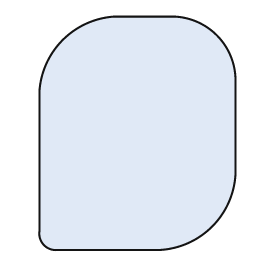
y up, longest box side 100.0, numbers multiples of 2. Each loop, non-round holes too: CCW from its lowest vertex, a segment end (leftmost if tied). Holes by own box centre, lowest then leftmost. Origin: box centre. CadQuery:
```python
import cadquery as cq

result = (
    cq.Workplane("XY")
    .moveTo(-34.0, -50.0)
    .lineTo(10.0, -50.0)
    .threePointArc((32.0, -40.0), (42.0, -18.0))
    .lineTo(42.0, 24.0)
    .threePointArc((34.0, 42.0), (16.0, 50.0))
    .lineTo(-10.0, 50.0)
    .threePointArc((-32.0, 40.0), (-42.0, 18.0))
    .lineTo(-42.0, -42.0)
    .threePointArc((-40.0, -48.0), (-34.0, -50.0))
    .close()
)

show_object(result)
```